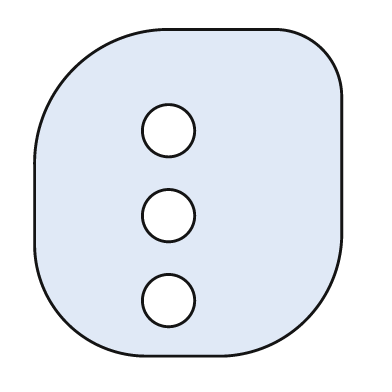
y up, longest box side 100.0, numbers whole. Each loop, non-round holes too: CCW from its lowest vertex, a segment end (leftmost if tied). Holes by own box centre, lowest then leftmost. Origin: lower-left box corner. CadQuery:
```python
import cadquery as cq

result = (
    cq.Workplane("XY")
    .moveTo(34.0, 0.0)
    .lineTo(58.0, 0.0)
    .threePointArc((83.0, 11.0), (94.0, 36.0))
    .lineTo(94.0, 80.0)
    .threePointArc((88.0, 94.0), (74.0, 100.0))
    .lineTo(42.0, 100.0)
    .threePointArc((12.0, 88.0), (0.0, 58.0))
    .lineTo(0.0, 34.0)
    .threePointArc((10.0, 10.0), (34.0, 0.0))
    .close()
    .moveTo(41.0, 17.0)
    .circle(8.0)
    .moveTo(41.0, 43.0)
    .circle(8.0)
    .moveTo(41.0, 69.0)
    .circle(8.0)
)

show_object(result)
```